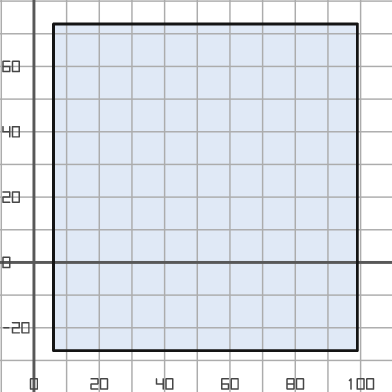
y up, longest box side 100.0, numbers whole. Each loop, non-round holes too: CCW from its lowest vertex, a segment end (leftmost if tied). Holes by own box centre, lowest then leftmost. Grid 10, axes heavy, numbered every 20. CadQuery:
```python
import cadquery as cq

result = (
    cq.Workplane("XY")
    .moveTo(6.0, -27.0)
    .lineTo(99.0, -27.0)
    .lineTo(99.0, 73.0)
    .lineTo(6.0, 73.0)
    .close()
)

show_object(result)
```